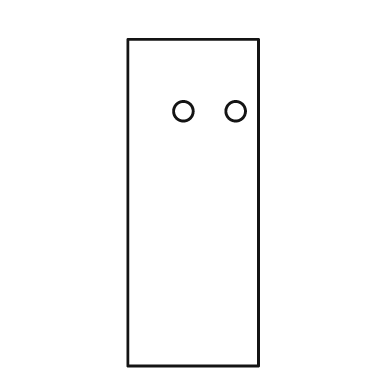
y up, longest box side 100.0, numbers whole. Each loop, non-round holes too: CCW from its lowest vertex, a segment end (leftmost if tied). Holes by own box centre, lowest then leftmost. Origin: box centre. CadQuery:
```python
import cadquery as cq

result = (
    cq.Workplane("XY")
    .moveTo(-20.0, -50.0)
    .lineTo(20.0, -50.0)
    .lineTo(20.0, 50.0)
    .lineTo(-20.0, 50.0)
    .close()
    .moveTo(-3.0, 28.0)
    .circle(3.0)
    .moveTo(13.0, 28.0)
    .circle(3.0)
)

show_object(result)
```